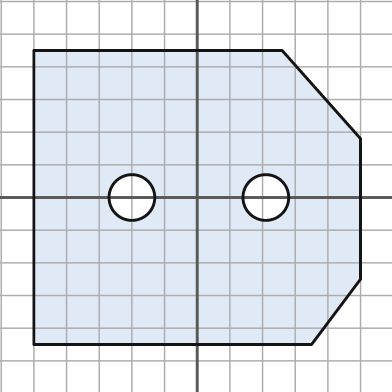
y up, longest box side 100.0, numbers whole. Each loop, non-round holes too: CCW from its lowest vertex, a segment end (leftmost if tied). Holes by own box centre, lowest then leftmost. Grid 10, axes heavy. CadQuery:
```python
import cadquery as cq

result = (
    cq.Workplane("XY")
    .moveTo(-50.0, -45.0)
    .lineTo(35.0, -45.0)
    .lineTo(50.0, -25.0)
    .lineTo(50.0, 18.0)
    .lineTo(26.0, 45.0)
    .lineTo(-50.0, 45.0)
    .close()
    .moveTo(-20.0, 0.0)
    .circle(7.0)
    .moveTo(21.0, 0.0)
    .circle(7.0)
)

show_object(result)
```